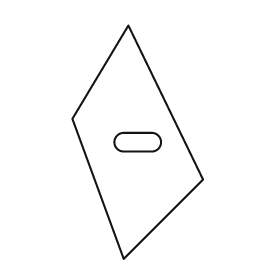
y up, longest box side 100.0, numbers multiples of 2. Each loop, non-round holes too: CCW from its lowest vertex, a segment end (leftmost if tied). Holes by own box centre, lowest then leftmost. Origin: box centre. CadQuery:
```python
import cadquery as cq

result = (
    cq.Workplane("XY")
    .moveTo(-6.0, -50.0)
    .lineTo(28.0, -16.0)
    .lineTo(-4.0, 50.0)
    .lineTo(-28.0, 10.0)
    .close()
    .moveTo(-6.0, -4.0)
    .lineTo(6.0, -4.0)
    .threePointArc((10.0, 0.0), (6.0, 4.0))
    .lineTo(-6.0, 4.0)
    .threePointArc((-10.0, 0.0), (-6.0, -4.0))
    .close()
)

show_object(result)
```